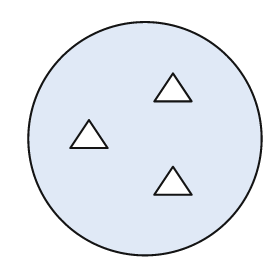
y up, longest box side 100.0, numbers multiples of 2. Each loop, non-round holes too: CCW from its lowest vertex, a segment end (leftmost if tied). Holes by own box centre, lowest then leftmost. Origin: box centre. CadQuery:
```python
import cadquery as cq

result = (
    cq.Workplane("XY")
    .moveTo(0.0, 0.0)
    .circle(50.0)
    .moveTo(4.0, -24.0)
    .lineTo(20.0, -24.0)
    .lineTo(12.0, -12.0)
    .close()
    .moveTo(-32.0, -4.0)
    .lineTo(-16.0, -4.0)
    .lineTo(-24.0, 8.0)
    .close()
    .moveTo(4.0, 16.0)
    .lineTo(20.0, 16.0)
    .lineTo(12.0, 28.0)
    .close()
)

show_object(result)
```